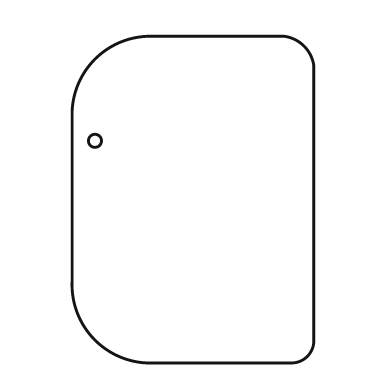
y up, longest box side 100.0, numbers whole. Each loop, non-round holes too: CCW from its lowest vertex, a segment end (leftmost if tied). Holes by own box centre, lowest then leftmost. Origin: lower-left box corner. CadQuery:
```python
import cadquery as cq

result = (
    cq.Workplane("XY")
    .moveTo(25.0, 0.0)
    .lineTo(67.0, 0.0)
    .threePointArc((72.0, 2.0), (74.0, 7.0))
    .lineTo(74.0, 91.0)
    .threePointArc((71.0, 97.0), (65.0, 100.0))
    .lineTo(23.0, 100.0)
    .threePointArc((7.0, 93.0), (0.0, 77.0))
    .lineTo(0.0, 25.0)
    .threePointArc((7.0, 7.0), (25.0, 0.0))
    .close()
    .moveTo(7.0, 68.0)
    .circle(2.0)
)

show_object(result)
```